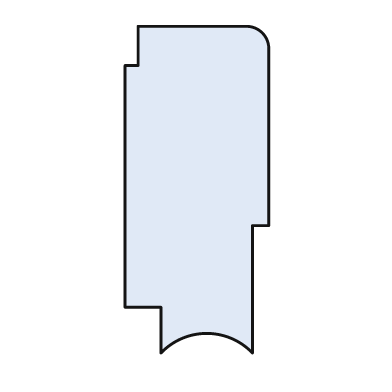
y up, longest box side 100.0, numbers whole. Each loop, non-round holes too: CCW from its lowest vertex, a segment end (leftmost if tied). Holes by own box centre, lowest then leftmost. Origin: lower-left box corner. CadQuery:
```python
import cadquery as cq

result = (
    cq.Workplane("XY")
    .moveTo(11.0, 0.0)
    .threePointArc((25.0, 6.0), (39.0, 0.0))
    .lineTo(39.0, 39.0)
    .lineTo(44.0, 39.0)
    .lineTo(44.0, 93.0)
    .threePointArc((42.0, 98.0), (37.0, 100.0))
    .lineTo(4.0, 100.0)
    .lineTo(4.0, 88.0)
    .lineTo(0.0, 88.0)
    .lineTo(0.0, 14.0)
    .lineTo(11.0, 14.0)
    .close()
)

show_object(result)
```